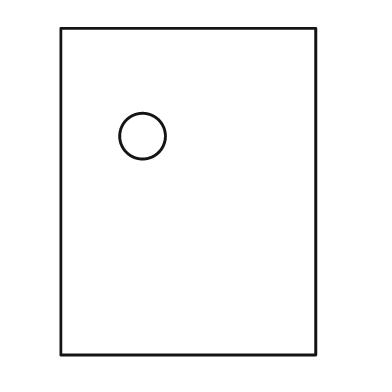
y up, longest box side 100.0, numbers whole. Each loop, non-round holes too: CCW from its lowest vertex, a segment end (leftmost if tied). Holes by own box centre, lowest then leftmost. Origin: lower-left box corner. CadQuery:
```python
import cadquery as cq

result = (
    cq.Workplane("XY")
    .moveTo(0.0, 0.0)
    .lineTo(78.0, 0.0)
    .lineTo(78.0, 100.0)
    .lineTo(0.0, 100.0)
    .close()
    .moveTo(25.0, 67.0)
    .circle(7.0)
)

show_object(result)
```